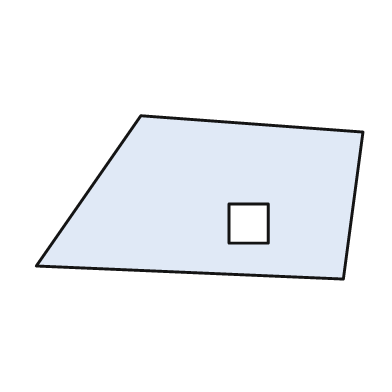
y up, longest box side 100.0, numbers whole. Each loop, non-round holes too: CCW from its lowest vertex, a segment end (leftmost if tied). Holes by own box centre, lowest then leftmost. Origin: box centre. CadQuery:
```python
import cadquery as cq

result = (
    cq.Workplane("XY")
    .moveTo(44.0, -25.0)
    .lineTo(50.0, 20.0)
    .lineTo(-18.0, 25.0)
    .lineTo(-50.0, -21.0)
    .close()
    .moveTo(9.0, -14.0)
    .lineTo(21.0, -14.0)
    .lineTo(21.0, -2.0)
    .lineTo(9.0, -2.0)
    .close()
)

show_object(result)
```